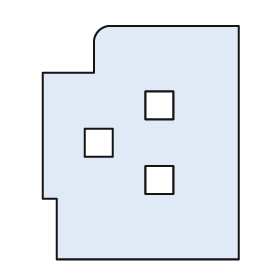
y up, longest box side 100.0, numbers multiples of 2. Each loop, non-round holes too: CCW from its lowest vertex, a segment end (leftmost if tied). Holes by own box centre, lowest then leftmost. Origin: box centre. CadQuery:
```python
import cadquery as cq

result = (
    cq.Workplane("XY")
    .moveTo(-36.0, -50.0)
    .lineTo(42.0, -50.0)
    .lineTo(42.0, 50.0)
    .lineTo(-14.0, 50.0)
    .threePointArc((-18.0, 48.0), (-20.0, 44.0))
    .lineTo(-20.0, 30.0)
    .lineTo(-42.0, 30.0)
    .lineTo(-42.0, -24.0)
    .lineTo(-36.0, -24.0)
    .close()
    .moveTo(2.0, -22.0)
    .lineTo(14.0, -22.0)
    .lineTo(14.0, -10.0)
    .lineTo(2.0, -10.0)
    .close()
    .moveTo(-24.0, -6.0)
    .lineTo(-12.0, -6.0)
    .lineTo(-12.0, 6.0)
    .lineTo(-24.0, 6.0)
    .close()
    .moveTo(2.0, 10.0)
    .lineTo(14.0, 10.0)
    .lineTo(14.0, 22.0)
    .lineTo(2.0, 22.0)
    .close()
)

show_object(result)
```